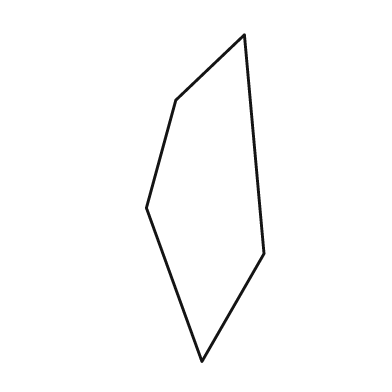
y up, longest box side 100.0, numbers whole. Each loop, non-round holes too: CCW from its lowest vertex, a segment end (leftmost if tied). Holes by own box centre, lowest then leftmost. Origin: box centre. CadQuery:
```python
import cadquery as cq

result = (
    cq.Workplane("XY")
    .moveTo(-1.0, -50.0)
    .lineTo(18.0, -17.0)
    .lineTo(12.0, 50.0)
    .lineTo(-9.0, 30.0)
    .lineTo(-18.0, -3.0)
    .close()
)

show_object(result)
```